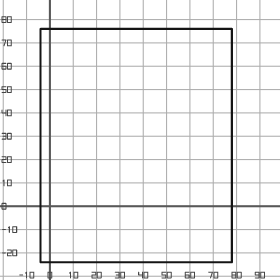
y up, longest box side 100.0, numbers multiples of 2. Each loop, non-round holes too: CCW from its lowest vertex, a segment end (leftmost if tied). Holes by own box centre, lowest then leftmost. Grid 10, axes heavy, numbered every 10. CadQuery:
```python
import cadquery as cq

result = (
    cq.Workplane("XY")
    .moveTo(-4.0, -24.0)
    .lineTo(78.0, -24.0)
    .lineTo(78.0, 76.0)
    .lineTo(-4.0, 76.0)
    .close()
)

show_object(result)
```